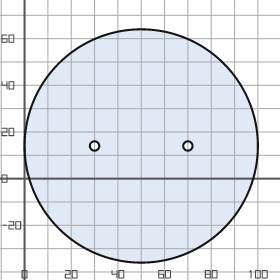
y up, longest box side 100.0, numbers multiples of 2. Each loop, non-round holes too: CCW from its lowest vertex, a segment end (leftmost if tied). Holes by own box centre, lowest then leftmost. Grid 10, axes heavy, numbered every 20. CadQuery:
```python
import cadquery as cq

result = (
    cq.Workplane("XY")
    .moveTo(50.0, 14.0)
    .circle(50.0)
    .moveTo(30.0, 14.0)
    .circle(2.0)
    .moveTo(70.0, 14.0)
    .circle(2.0)
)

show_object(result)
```